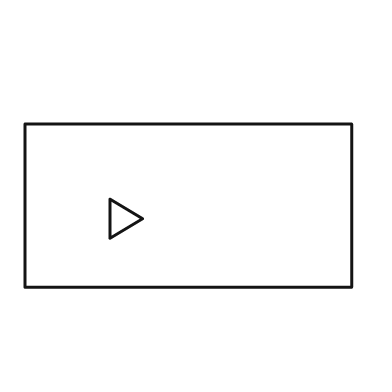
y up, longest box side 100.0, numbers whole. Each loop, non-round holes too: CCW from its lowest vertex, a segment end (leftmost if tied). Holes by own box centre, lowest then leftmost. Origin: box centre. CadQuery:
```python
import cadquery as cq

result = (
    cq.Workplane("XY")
    .moveTo(-50.0, -25.0)
    .lineTo(50.0, -25.0)
    .lineTo(50.0, 25.0)
    .lineTo(-50.0, 25.0)
    .close()
    .moveTo(-24.0, -10.0)
    .lineTo(-14.0, -4.0)
    .lineTo(-24.0, 2.0)
    .close()
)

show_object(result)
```